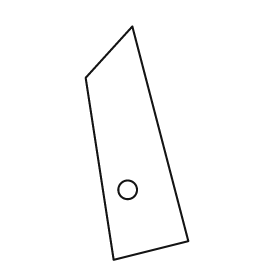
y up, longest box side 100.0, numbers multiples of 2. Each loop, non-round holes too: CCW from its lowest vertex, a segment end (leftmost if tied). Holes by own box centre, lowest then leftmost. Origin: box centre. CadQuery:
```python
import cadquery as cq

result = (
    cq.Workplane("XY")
    .moveTo(-10.0, -50.0)
    .lineTo(22.0, -42.0)
    .lineTo(-2.0, 50.0)
    .lineTo(-22.0, 28.0)
    .close()
    .moveTo(-4.0, -20.0)
    .circle(4.0)
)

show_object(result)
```